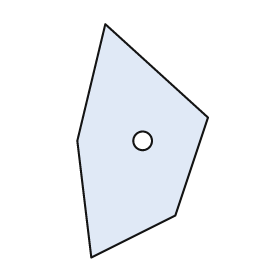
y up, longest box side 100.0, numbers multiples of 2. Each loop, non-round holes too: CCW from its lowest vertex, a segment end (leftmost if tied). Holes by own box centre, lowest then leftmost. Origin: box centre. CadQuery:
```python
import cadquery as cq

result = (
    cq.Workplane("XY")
    .moveTo(-22.0, -50.0)
    .lineTo(14.0, -32.0)
    .lineTo(28.0, 10.0)
    .lineTo(-16.0, 50.0)
    .lineTo(-28.0, 0.0)
    .close()
    .moveTo(0.0, 0.0)
    .circle(4.0)
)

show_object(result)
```